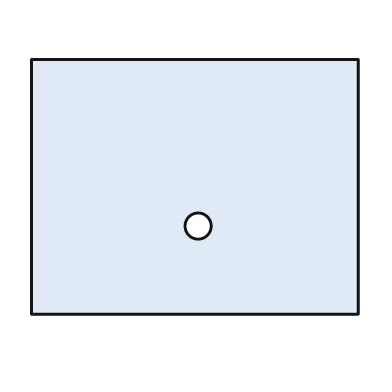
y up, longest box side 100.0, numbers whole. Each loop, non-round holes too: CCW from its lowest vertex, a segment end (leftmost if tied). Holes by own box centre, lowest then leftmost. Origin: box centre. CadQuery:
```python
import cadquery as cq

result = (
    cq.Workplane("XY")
    .moveTo(-50.0, -39.0)
    .lineTo(50.0, -39.0)
    .lineTo(50.0, 39.0)
    .lineTo(-50.0, 39.0)
    .close()
    .moveTo(1.0, -12.0)
    .circle(4.0)
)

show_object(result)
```